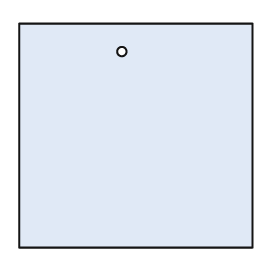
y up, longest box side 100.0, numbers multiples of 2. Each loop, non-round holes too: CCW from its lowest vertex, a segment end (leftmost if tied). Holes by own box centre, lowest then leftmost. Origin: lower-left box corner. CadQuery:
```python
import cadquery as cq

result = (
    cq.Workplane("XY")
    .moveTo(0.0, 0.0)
    .lineTo(100.0, 0.0)
    .lineTo(100.0, 96.0)
    .lineTo(0.0, 96.0)
    .close()
    .moveTo(44.0, 84.0)
    .circle(2.0)
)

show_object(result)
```